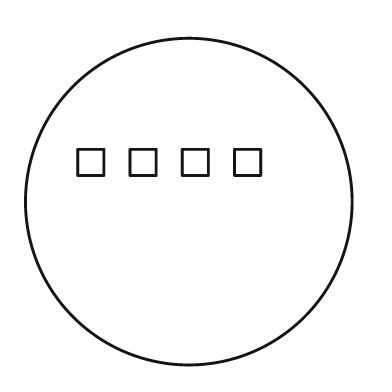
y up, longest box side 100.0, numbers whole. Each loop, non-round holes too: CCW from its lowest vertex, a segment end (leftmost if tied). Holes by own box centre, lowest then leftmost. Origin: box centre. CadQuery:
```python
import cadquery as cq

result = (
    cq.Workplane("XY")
    .moveTo(0.0, 0.0)
    .circle(50.0)
    .moveTo(-34.0, 8.0)
    .lineTo(-26.0, 8.0)
    .lineTo(-26.0, 16.0)
    .lineTo(-34.0, 16.0)
    .close()
    .moveTo(-18.0, 8.0)
    .lineTo(-10.0, 8.0)
    .lineTo(-10.0, 16.0)
    .lineTo(-18.0, 16.0)
    .close()
    .moveTo(-2.0, 8.0)
    .lineTo(6.0, 8.0)
    .lineTo(6.0, 16.0)
    .lineTo(-2.0, 16.0)
    .close()
    .moveTo(14.0, 8.0)
    .lineTo(22.0, 8.0)
    .lineTo(22.0, 16.0)
    .lineTo(14.0, 16.0)
    .close()
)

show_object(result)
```